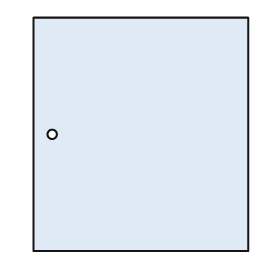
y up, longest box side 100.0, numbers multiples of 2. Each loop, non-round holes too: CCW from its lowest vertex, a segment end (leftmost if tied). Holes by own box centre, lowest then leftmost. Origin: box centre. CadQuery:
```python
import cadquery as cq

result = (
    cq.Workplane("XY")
    .moveTo(-46.0, -50.0)
    .lineTo(46.0, -50.0)
    .lineTo(46.0, 50.0)
    .lineTo(-46.0, 50.0)
    .close()
    .moveTo(-38.0, 0.0)
    .circle(2.0)
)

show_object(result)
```